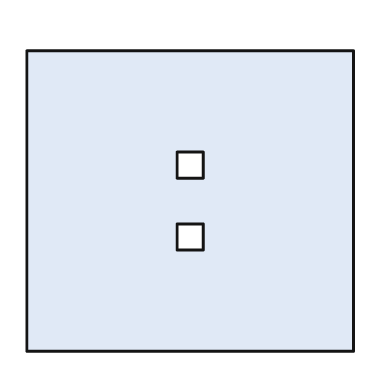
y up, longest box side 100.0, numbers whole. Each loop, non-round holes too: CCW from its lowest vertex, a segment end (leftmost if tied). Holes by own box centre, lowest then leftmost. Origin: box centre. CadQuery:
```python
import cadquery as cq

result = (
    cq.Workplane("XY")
    .moveTo(-50.0, -46.0)
    .lineTo(50.0, -46.0)
    .lineTo(50.0, 46.0)
    .lineTo(-50.0, 46.0)
    .close()
    .moveTo(-4.0, -15.0)
    .lineTo(4.0, -15.0)
    .lineTo(4.0, -7.0)
    .lineTo(-4.0, -7.0)
    .close()
    .moveTo(-4.0, 7.0)
    .lineTo(4.0, 7.0)
    .lineTo(4.0, 15.0)
    .lineTo(-4.0, 15.0)
    .close()
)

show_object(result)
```